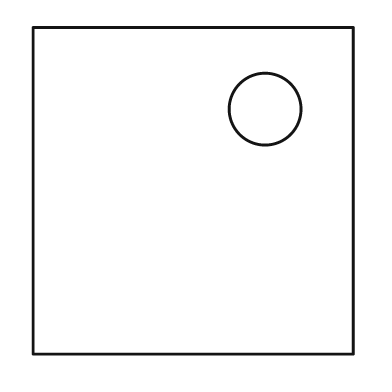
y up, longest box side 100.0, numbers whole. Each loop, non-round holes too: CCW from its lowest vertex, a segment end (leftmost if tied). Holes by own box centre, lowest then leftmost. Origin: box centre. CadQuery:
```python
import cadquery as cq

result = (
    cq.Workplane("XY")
    .moveTo(-49.0, -50.0)
    .lineTo(49.0, -50.0)
    .lineTo(49.0, 50.0)
    .lineTo(-49.0, 50.0)
    .close()
    .moveTo(22.0, 25.0)
    .circle(11.0)
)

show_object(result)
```